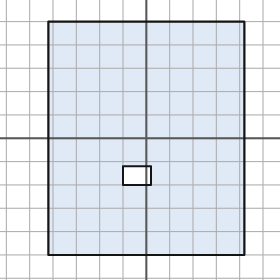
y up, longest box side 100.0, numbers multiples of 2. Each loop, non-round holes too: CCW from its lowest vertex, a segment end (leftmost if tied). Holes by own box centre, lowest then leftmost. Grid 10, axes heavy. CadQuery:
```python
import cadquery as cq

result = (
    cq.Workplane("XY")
    .moveTo(-42.0, -50.0)
    .lineTo(42.0, -50.0)
    .lineTo(42.0, 50.0)
    .lineTo(-42.0, 50.0)
    .close()
    .moveTo(-10.0, -20.0)
    .lineTo(2.0, -20.0)
    .lineTo(2.0, -12.0)
    .lineTo(-10.0, -12.0)
    .close()
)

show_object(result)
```